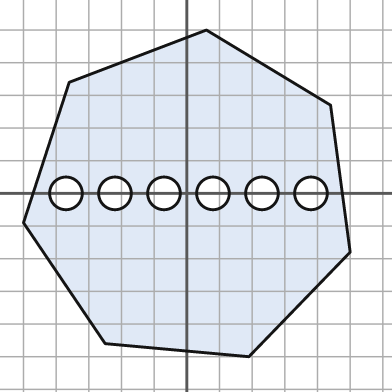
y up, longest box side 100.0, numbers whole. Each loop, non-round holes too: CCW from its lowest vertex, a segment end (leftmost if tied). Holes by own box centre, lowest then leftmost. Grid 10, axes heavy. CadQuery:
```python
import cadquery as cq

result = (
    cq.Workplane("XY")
    .moveTo(19.0, -50.0)
    .lineTo(50.0, -18.0)
    .lineTo(44.0, 27.0)
    .lineTo(6.0, 50.0)
    .lineTo(-36.0, 34.0)
    .lineTo(-50.0, -9.0)
    .lineTo(-25.0, -46.0)
    .close()
    .moveTo(-37.0, 0.0)
    .circle(5.0)
    .moveTo(-22.0, 0.0)
    .circle(5.0)
    .moveTo(-7.0, 0.0)
    .circle(5.0)
    .moveTo(8.0, 0.0)
    .circle(5.0)
    .moveTo(23.0, 0.0)
    .circle(5.0)
    .moveTo(38.0, 0.0)
    .circle(5.0)
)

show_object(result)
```